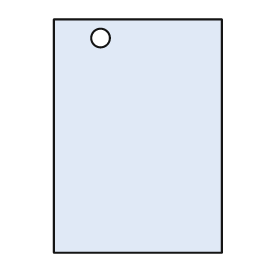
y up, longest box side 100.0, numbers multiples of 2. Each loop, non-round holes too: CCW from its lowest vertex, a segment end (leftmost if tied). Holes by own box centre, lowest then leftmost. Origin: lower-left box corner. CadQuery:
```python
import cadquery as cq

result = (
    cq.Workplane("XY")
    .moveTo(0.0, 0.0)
    .lineTo(72.0, 0.0)
    .lineTo(72.0, 100.0)
    .lineTo(0.0, 100.0)
    .close()
    .moveTo(20.0, 92.0)
    .circle(4.0)
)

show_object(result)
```